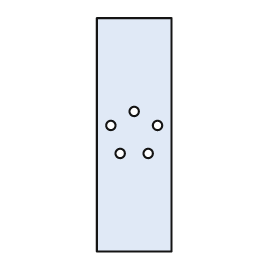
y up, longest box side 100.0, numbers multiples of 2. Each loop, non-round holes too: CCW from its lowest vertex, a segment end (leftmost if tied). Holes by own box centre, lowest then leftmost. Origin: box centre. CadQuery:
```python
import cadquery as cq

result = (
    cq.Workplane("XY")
    .moveTo(-16.0, -50.0)
    .lineTo(16.0, -50.0)
    .lineTo(16.0, 50.0)
    .lineTo(-16.0, 50.0)
    .close()
    .moveTo(-6.0, -8.0)
    .circle(2.0)
    .moveTo(6.0, -8.0)
    .circle(2.0)
    .moveTo(-10.0, 4.0)
    .circle(2.0)
    .moveTo(10.0, 4.0)
    .circle(2.0)
    .moveTo(0.0, 10.0)
    .circle(2.0)
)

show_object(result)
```